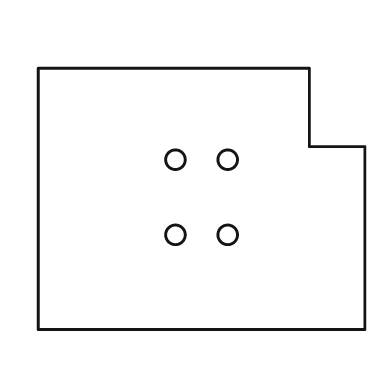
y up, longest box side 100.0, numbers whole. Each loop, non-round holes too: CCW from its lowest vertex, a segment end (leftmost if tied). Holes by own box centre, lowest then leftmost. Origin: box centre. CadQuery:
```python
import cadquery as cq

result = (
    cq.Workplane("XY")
    .moveTo(-50.0, -40.0)
    .lineTo(50.0, -40.0)
    .lineTo(50.0, 16.0)
    .lineTo(33.0, 16.0)
    .lineTo(33.0, 40.0)
    .lineTo(-50.0, 40.0)
    .close()
    .moveTo(-8.0, -11.0)
    .circle(3.0)
    .moveTo(8.0, -11.0)
    .circle(3.0)
    .moveTo(-8.0, 12.0)
    .circle(3.0)
    .moveTo(8.0, 12.0)
    .circle(3.0)
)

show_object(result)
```